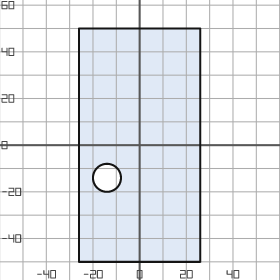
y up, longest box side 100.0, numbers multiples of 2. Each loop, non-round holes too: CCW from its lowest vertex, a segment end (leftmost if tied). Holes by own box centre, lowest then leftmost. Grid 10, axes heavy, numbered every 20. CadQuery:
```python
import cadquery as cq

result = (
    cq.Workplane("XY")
    .moveTo(-26.0, -50.0)
    .lineTo(26.0, -50.0)
    .lineTo(26.0, 50.0)
    .lineTo(-26.0, 50.0)
    .close()
    .moveTo(-14.0, -14.0)
    .circle(6.0)
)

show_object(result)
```